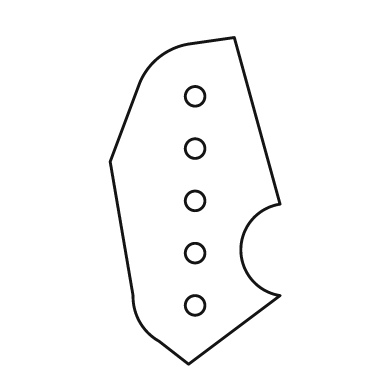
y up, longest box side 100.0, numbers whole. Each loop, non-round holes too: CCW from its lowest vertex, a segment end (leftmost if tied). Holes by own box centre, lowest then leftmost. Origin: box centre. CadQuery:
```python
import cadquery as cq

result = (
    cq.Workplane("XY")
    .moveTo(-2.0, -50.0)
    .lineTo(26.0, -29.0)
    .threePointArc((14.0, -15.0), (26.0, -1.0))
    .lineTo(12.0, 50.0)
    .lineTo(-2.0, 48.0)
    .threePointArc((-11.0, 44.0), (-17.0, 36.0))
    .lineTo(-26.0, 12.0)
    .lineTo(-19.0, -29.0)
    .threePointArc((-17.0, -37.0), (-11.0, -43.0))
    .close()
    .moveTo(0.0, -32.0)
    .circle(3.0)
    .moveTo(0.0, -16.0)
    .circle(3.0)
    .moveTo(0.0, 0.0)
    .circle(3.0)
    .moveTo(0.0, 16.0)
    .circle(3.0)
    .moveTo(0.0, 32.0)
    .circle(3.0)
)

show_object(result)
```